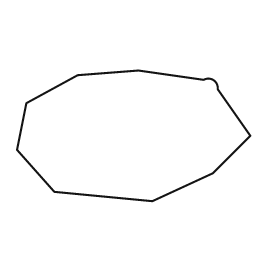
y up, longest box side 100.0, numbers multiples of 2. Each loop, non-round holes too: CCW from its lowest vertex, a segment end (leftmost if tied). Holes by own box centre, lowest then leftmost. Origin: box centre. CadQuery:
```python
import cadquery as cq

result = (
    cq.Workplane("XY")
    .moveTo(8.0, -28.0)
    .lineTo(34.0, -16.0)
    .lineTo(50.0, 0.0)
    .lineTo(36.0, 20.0)
    .threePointArc((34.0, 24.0), (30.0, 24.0))
    .lineTo(2.0, 28.0)
    .lineTo(-24.0, 26.0)
    .lineTo(-46.0, 14.0)
    .lineTo(-50.0, -6.0)
    .lineTo(-34.0, -24.0)
    .close()
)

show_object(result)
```